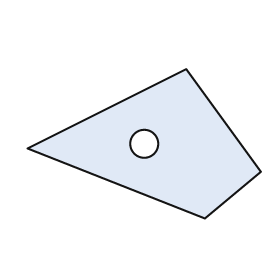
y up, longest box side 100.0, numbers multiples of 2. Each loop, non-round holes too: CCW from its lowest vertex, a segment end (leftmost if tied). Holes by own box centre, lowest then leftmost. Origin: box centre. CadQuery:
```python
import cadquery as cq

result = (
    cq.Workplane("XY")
    .moveTo(26.0, -32.0)
    .lineTo(50.0, -12.0)
    .lineTo(18.0, 32.0)
    .lineTo(-50.0, -2.0)
    .close()
    .moveTo(0.0, 0.0)
    .circle(6.0)
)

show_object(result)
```